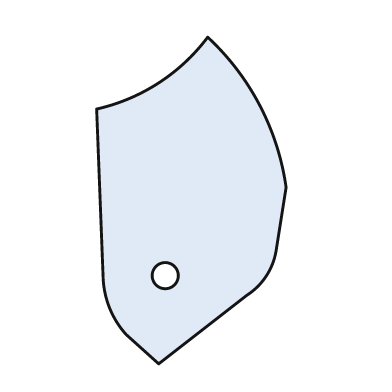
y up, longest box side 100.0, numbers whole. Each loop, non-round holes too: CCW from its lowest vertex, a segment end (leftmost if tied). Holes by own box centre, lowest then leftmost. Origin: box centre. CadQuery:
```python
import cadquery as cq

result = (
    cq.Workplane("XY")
    .moveTo(-10.0, -50.0)
    .lineTo(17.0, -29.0)
    .threePointArc((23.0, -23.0), (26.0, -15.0))
    .lineTo(29.0, 4.0)
    .threePointArc((21.0, 29.0), (5.0, 50.0))
    .threePointArc((-10.0, 36.0), (-29.0, 28.0))
    .lineTo(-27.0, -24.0)
    .threePointArc((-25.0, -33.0), (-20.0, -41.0))
    .close()
    .moveTo(-8.0, -23.0)
    .circle(4.0)
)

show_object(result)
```